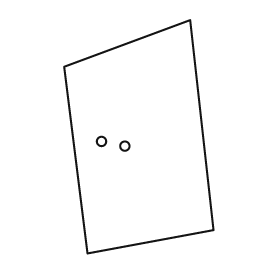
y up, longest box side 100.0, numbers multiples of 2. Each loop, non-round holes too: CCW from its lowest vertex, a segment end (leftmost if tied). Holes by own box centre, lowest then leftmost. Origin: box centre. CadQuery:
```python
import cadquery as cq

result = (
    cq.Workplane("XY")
    .moveTo(-22.0, -50.0)
    .lineTo(32.0, -40.0)
    .lineTo(22.0, 50.0)
    .lineTo(-32.0, 30.0)
    .close()
    .moveTo(-6.0, -4.0)
    .circle(2.0)
    .moveTo(-16.0, -2.0)
    .circle(2.0)
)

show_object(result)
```